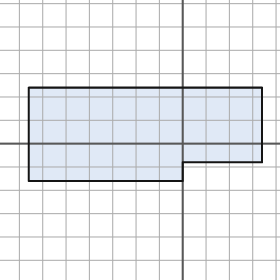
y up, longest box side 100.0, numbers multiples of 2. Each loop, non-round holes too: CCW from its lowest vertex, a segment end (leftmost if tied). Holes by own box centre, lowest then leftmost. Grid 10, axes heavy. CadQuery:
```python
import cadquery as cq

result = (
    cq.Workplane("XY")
    .moveTo(-66.0, -16.0)
    .lineTo(0.0, -16.0)
    .lineTo(0.0, -8.0)
    .lineTo(34.0, -8.0)
    .lineTo(34.0, 24.0)
    .lineTo(-66.0, 24.0)
    .close()
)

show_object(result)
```